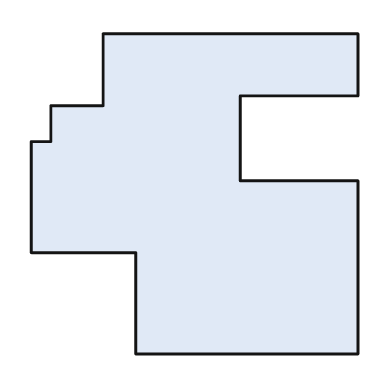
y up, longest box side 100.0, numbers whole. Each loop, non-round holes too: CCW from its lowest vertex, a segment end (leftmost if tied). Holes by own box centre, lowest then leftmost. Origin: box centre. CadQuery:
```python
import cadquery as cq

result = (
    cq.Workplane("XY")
    .moveTo(-18.0, -49.0)
    .lineTo(50.0, -49.0)
    .lineTo(50.0, 4.0)
    .lineTo(14.0, 4.0)
    .lineTo(14.0, 30.0)
    .lineTo(50.0, 30.0)
    .lineTo(50.0, 49.0)
    .lineTo(-28.0, 49.0)
    .lineTo(-28.0, 27.0)
    .lineTo(-44.0, 27.0)
    .lineTo(-44.0, 16.0)
    .lineTo(-50.0, 16.0)
    .lineTo(-50.0, -18.0)
    .lineTo(-18.0, -18.0)
    .close()
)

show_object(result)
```